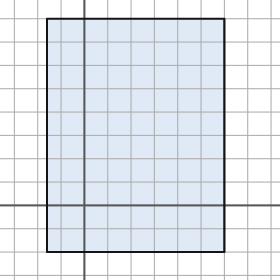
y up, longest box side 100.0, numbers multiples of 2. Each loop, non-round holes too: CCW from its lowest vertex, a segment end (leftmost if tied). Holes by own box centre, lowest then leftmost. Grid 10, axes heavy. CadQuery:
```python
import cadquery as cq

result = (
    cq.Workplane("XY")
    .moveTo(-16.0, -20.0)
    .lineTo(60.0, -20.0)
    .lineTo(60.0, 80.0)
    .lineTo(-16.0, 80.0)
    .close()
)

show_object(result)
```